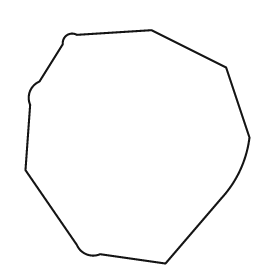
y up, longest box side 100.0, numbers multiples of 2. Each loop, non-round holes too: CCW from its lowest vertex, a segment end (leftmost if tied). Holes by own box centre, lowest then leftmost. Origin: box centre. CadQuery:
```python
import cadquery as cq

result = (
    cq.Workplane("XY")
    .moveTo(12.0, -50.0)
    .lineTo(36.0, -22.0)
    .threePointArc((44.0, -10.0), (48.0, 4.0))
    .lineTo(38.0, 34.0)
    .lineTo(6.0, 50.0)
    .lineTo(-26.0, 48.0)
    .threePointArc((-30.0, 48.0), (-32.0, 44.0))
    .lineTo(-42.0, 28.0)
    .threePointArc((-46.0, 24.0), (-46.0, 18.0))
    .lineTo(-48.0, -10.0)
    .lineTo(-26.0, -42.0)
    .threePointArc((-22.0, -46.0), (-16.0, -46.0))
    .close()
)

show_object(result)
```